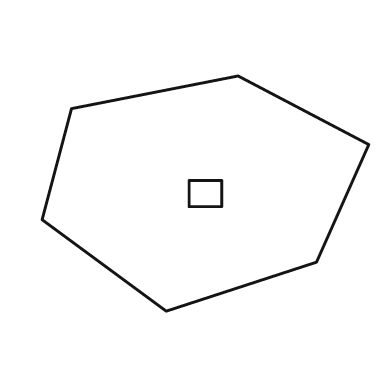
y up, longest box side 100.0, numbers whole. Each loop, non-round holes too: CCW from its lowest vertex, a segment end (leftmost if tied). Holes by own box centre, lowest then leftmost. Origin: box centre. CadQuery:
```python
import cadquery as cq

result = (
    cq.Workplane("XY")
    .moveTo(-12.0, -36.0)
    .lineTo(34.0, -21.0)
    .lineTo(50.0, 15.0)
    .lineTo(10.0, 36.0)
    .lineTo(-41.0, 26.0)
    .lineTo(-50.0, -8.0)
    .close()
    .moveTo(-5.0, -4.0)
    .lineTo(5.0, -4.0)
    .lineTo(5.0, 4.0)
    .lineTo(-5.0, 4.0)
    .close()
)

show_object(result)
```